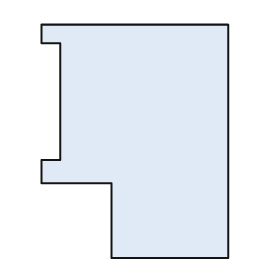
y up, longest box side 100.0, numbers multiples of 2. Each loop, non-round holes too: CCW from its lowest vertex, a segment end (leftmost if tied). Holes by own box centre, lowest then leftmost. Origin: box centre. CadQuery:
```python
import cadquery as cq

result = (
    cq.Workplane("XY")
    .moveTo(-10.0, -50.0)
    .lineTo(40.0, -50.0)
    .lineTo(40.0, 50.0)
    .lineTo(-40.0, 50.0)
    .lineTo(-40.0, 42.0)
    .lineTo(-32.0, 42.0)
    .lineTo(-32.0, -8.0)
    .lineTo(-40.0, -8.0)
    .lineTo(-40.0, -18.0)
    .lineTo(-10.0, -18.0)
    .close()
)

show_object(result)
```